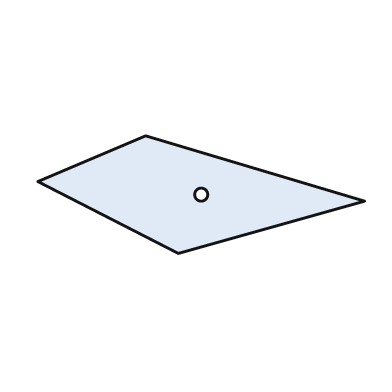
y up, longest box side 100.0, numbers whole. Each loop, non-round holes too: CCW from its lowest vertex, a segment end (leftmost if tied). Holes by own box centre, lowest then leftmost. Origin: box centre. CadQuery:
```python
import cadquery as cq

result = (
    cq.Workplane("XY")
    .moveTo(-7.0, -18.0)
    .lineTo(50.0, -2.0)
    .lineTo(-17.0, 18.0)
    .lineTo(-50.0, 4.0)
    .close()
    .moveTo(0.0, 0.0)
    .circle(2.0)
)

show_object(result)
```